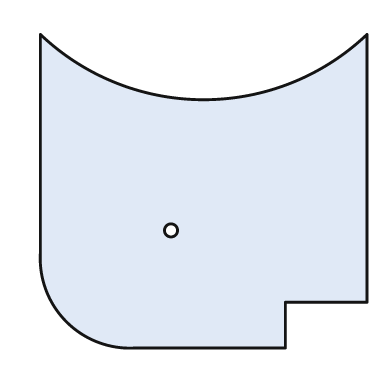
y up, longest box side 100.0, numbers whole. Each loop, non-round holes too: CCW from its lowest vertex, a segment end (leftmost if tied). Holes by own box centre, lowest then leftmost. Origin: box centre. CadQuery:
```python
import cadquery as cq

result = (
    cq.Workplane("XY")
    .moveTo(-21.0, -48.0)
    .lineTo(25.0, -48.0)
    .lineTo(25.0, -34.0)
    .lineTo(50.0, -34.0)
    .lineTo(50.0, 48.0)
    .threePointArc((0.0, 28.0), (-50.0, 48.0))
    .lineTo(-50.0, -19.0)
    .threePointArc((-42.0, -40.0), (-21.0, -48.0))
    .close()
    .moveTo(-10.0, -12.0)
    .circle(2.0)
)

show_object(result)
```